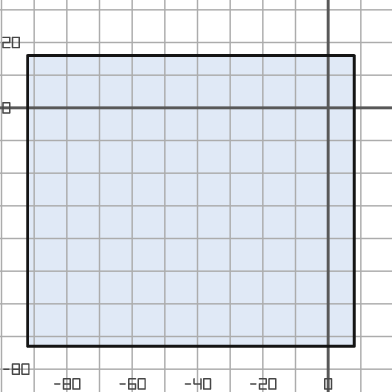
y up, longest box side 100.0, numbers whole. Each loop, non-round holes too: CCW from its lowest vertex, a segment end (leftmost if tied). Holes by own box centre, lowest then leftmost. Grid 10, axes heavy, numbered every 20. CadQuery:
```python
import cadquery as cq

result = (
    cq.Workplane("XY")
    .moveTo(-92.0, -73.0)
    .lineTo(8.0, -73.0)
    .lineTo(8.0, 16.0)
    .lineTo(-92.0, 16.0)
    .close()
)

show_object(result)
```